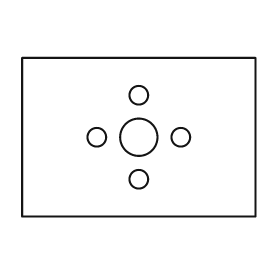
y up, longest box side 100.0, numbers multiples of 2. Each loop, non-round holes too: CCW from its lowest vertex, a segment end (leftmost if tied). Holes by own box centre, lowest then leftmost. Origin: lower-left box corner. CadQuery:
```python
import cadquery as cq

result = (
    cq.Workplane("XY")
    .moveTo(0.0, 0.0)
    .lineTo(100.0, 0.0)
    .lineTo(100.0, 68.0)
    .lineTo(0.0, 68.0)
    .close()
    .moveTo(50.0, 16.0)
    .circle(4.0)
    .moveTo(32.0, 34.0)
    .circle(4.0)
    .moveTo(50.0, 34.0)
    .circle(8.0)
    .moveTo(68.0, 34.0)
    .circle(4.0)
    .moveTo(50.0, 52.0)
    .circle(4.0)
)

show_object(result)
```